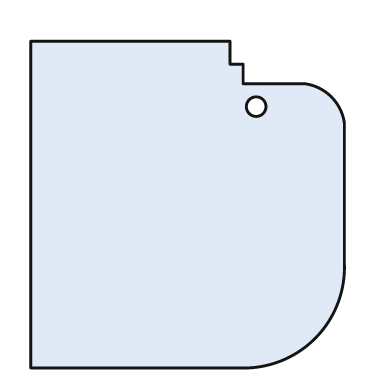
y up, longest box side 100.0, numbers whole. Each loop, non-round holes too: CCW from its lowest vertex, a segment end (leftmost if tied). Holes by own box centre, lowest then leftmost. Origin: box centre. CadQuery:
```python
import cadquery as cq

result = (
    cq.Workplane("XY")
    .moveTo(-48.0, -50.0)
    .lineTo(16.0, -50.0)
    .threePointArc((39.0, -41.0), (48.0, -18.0))
    .lineTo(48.0, 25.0)
    .threePointArc((44.0, 33.0), (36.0, 37.0))
    .lineTo(17.0, 37.0)
    .lineTo(17.0, 43.0)
    .lineTo(13.0, 43.0)
    .lineTo(13.0, 50.0)
    .lineTo(-48.0, 50.0)
    .close()
    .moveTo(21.0, 30.0)
    .circle(3.0)
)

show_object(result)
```